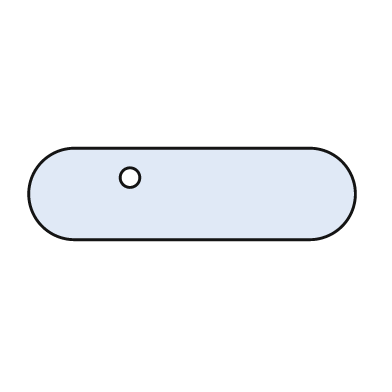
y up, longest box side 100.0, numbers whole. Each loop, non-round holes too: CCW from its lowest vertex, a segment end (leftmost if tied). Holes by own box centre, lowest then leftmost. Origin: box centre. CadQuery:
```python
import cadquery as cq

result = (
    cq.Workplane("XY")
    .moveTo(-36.0, -14.0)
    .lineTo(36.0, -14.0)
    .threePointArc((50.0, 0.0), (36.0, 14.0))
    .lineTo(-36.0, 14.0)
    .threePointArc((-50.0, 0.0), (-36.0, -14.0))
    .close()
    .moveTo(-19.0, 5.0)
    .circle(3.0)
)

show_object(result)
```